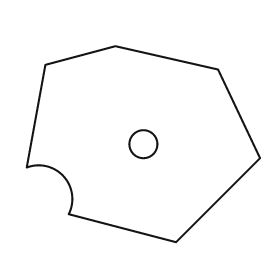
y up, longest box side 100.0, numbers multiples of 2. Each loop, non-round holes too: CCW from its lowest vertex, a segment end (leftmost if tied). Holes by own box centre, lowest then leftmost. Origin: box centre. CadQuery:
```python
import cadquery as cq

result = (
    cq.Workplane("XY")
    .moveTo(14.0, -42.0)
    .lineTo(50.0, -6.0)
    .lineTo(32.0, 32.0)
    .lineTo(-12.0, 42.0)
    .lineTo(-42.0, 34.0)
    .lineTo(-50.0, -10.0)
    .threePointArc((-34.0, -14.0), (-32.0, -30.0))
    .close()
    .moveTo(0.0, 0.0)
    .circle(6.0)
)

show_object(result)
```